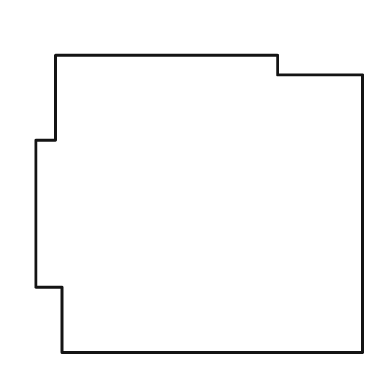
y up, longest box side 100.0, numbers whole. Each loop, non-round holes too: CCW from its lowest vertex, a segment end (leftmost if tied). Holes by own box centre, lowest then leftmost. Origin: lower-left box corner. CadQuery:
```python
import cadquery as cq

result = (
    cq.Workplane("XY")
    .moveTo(8.0, 0.0)
    .lineTo(100.0, 0.0)
    .lineTo(100.0, 85.0)
    .lineTo(74.0, 85.0)
    .lineTo(74.0, 91.0)
    .lineTo(6.0, 91.0)
    .lineTo(6.0, 65.0)
    .lineTo(0.0, 65.0)
    .lineTo(0.0, 20.0)
    .lineTo(8.0, 20.0)
    .close()
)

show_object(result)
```